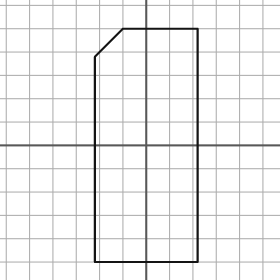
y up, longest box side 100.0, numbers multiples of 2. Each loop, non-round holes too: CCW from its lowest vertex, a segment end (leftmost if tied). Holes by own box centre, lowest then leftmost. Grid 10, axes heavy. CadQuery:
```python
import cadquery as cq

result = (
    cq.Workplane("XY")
    .moveTo(-22.0, -50.0)
    .lineTo(22.0, -50.0)
    .lineTo(22.0, 50.0)
    .lineTo(-10.0, 50.0)
    .lineTo(-22.0, 38.0)
    .close()
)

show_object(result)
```